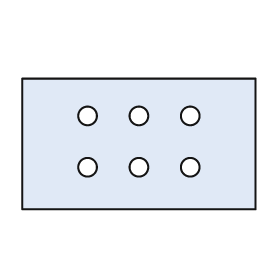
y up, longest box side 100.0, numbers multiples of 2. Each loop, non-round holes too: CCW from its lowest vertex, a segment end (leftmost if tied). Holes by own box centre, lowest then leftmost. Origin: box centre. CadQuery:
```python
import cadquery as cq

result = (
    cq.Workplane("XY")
    .moveTo(-50.0, -28.0)
    .lineTo(50.0, -28.0)
    .lineTo(50.0, 28.0)
    .lineTo(-50.0, 28.0)
    .close()
    .moveTo(-22.0, -10.0)
    .circle(4.0)
    .moveTo(0.0, -10.0)
    .circle(4.0)
    .moveTo(22.0, -10.0)
    .circle(4.0)
    .moveTo(-22.0, 12.0)
    .circle(4.0)
    .moveTo(0.0, 12.0)
    .circle(4.0)
    .moveTo(22.0, 12.0)
    .circle(4.0)
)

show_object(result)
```